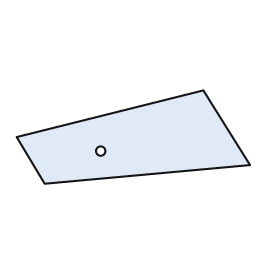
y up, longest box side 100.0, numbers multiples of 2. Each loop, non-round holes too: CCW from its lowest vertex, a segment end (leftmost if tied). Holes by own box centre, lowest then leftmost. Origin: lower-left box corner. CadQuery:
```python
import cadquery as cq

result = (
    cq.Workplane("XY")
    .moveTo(12.0, 0.0)
    .lineTo(100.0, 8.0)
    .lineTo(80.0, 40.0)
    .lineTo(0.0, 20.0)
    .close()
    .moveTo(36.0, 14.0)
    .circle(2.0)
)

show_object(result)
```